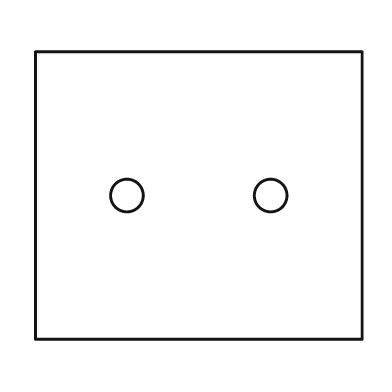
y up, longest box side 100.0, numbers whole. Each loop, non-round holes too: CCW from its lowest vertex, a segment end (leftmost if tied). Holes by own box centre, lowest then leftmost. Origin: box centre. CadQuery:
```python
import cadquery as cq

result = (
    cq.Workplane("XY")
    .moveTo(-50.0, -44.0)
    .lineTo(50.0, -44.0)
    .lineTo(50.0, 44.0)
    .lineTo(-50.0, 44.0)
    .close()
    .moveTo(-22.0, 0.0)
    .circle(5.0)
    .moveTo(22.0, 0.0)
    .circle(5.0)
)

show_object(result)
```